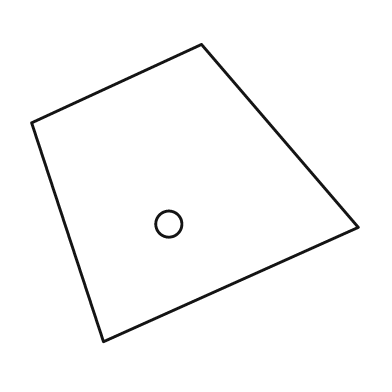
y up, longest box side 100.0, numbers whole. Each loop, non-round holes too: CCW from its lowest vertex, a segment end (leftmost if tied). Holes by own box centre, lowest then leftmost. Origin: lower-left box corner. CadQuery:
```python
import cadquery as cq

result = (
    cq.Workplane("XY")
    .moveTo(22.0, 0.0)
    .lineTo(100.0, 35.0)
    .lineTo(52.0, 91.0)
    .lineTo(0.0, 67.0)
    .close()
    .moveTo(42.0, 36.0)
    .circle(4.0)
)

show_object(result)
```